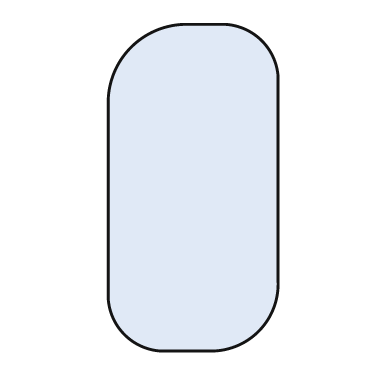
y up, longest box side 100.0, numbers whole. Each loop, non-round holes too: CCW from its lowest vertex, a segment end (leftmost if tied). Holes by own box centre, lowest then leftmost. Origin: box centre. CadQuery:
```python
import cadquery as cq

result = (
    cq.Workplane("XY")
    .moveTo(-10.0, -50.0)
    .lineTo(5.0, -50.0)
    .threePointArc((20.0, -44.0), (26.0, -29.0))
    .lineTo(26.0, 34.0)
    .threePointArc((21.0, 45.0), (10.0, 50.0))
    .lineTo(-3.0, 50.0)
    .threePointArc((-19.0, 43.0), (-26.0, 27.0))
    .lineTo(-26.0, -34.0)
    .threePointArc((-21.0, -45.0), (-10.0, -50.0))
    .close()
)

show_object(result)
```